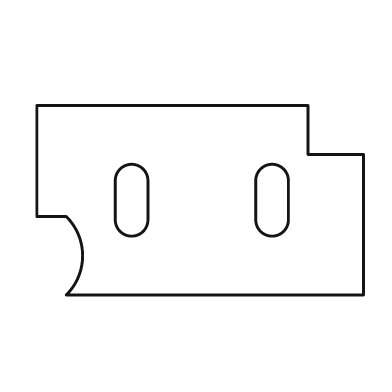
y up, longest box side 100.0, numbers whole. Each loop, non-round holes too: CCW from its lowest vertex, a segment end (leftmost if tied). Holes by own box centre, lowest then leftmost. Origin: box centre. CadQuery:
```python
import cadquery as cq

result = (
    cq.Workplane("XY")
    .moveTo(-41.0, -29.0)
    .lineTo(50.0, -29.0)
    .lineTo(50.0, 14.0)
    .lineTo(33.0, 14.0)
    .lineTo(33.0, 29.0)
    .lineTo(-50.0, 29.0)
    .lineTo(-50.0, -5.0)
    .lineTo(-41.0, -5.0)
    .threePointArc((-36.0, -17.0), (-41.0, -29.0))
    .close()
    .moveTo(-26.0, -6.0)
    .threePointArc((-21.0, -11.0), (-16.0, -6.0))
    .lineTo(-16.0, 6.0)
    .threePointArc((-21.0, 11.0), (-26.0, 6.0))
    .close()
    .moveTo(17.0, -6.0)
    .threePointArc((22.0, -11.0), (27.0, -6.0))
    .lineTo(27.0, 6.0)
    .threePointArc((22.0, 11.0), (17.0, 6.0))
    .close()
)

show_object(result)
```